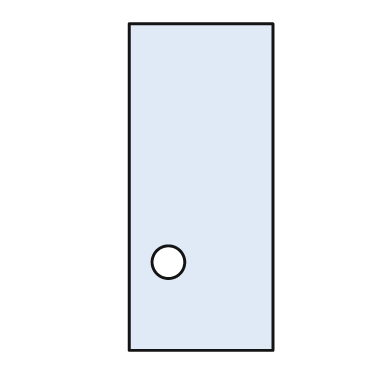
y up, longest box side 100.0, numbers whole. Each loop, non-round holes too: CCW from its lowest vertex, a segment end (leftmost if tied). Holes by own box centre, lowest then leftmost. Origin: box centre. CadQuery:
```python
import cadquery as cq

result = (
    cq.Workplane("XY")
    .moveTo(-22.0, -50.0)
    .lineTo(22.0, -50.0)
    .lineTo(22.0, 50.0)
    .lineTo(-22.0, 50.0)
    .close()
    .moveTo(-10.0, -23.0)
    .circle(5.0)
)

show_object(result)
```